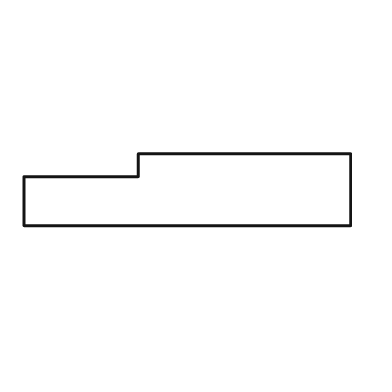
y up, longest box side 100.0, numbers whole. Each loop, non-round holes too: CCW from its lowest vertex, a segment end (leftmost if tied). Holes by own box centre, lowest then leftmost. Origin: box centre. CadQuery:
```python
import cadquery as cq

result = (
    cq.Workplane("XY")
    .moveTo(-50.0, -11.0)
    .lineTo(50.0, -11.0)
    .lineTo(50.0, 11.0)
    .lineTo(-15.0, 11.0)
    .lineTo(-15.0, 4.0)
    .lineTo(-50.0, 4.0)
    .close()
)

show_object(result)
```